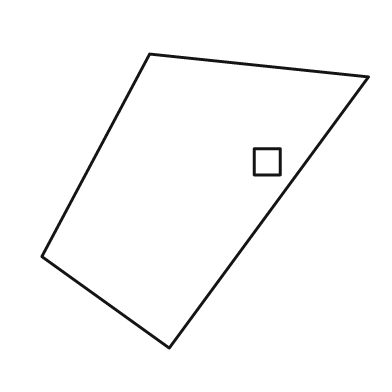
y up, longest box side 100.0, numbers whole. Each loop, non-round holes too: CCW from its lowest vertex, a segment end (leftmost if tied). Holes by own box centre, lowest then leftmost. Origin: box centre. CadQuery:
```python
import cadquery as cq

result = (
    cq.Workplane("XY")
    .moveTo(-11.0, -45.0)
    .lineTo(50.0, 38.0)
    .lineTo(-17.0, 45.0)
    .lineTo(-50.0, -17.0)
    .close()
    .moveTo(15.0, 8.0)
    .lineTo(23.0, 8.0)
    .lineTo(23.0, 16.0)
    .lineTo(15.0, 16.0)
    .close()
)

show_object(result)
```